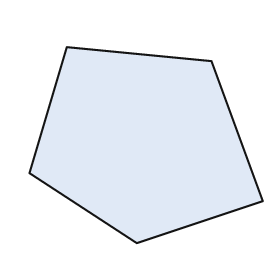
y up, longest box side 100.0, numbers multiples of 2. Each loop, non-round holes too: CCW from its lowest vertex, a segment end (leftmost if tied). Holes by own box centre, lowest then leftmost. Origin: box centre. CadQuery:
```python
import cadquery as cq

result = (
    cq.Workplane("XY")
    .moveTo(-4.0, -42.0)
    .lineTo(50.0, -24.0)
    .lineTo(28.0, 36.0)
    .lineTo(-34.0, 42.0)
    .lineTo(-50.0, -12.0)
    .close()
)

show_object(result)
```